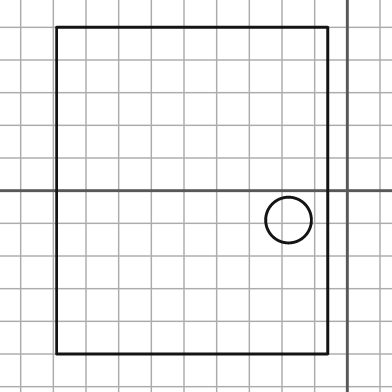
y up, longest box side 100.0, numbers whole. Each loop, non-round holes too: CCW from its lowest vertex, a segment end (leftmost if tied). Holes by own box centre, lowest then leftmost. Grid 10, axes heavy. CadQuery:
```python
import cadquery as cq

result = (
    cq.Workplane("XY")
    .moveTo(-89.0, -50.0)
    .lineTo(-6.0, -50.0)
    .lineTo(-6.0, 50.0)
    .lineTo(-89.0, 50.0)
    .close()
    .moveTo(-18.0, -9.0)
    .circle(7.0)
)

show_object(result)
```